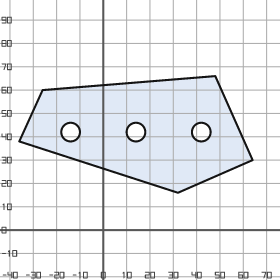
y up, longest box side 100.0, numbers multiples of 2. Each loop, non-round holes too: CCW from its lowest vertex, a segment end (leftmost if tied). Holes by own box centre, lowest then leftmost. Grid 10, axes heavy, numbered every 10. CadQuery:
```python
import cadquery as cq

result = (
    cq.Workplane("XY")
    .moveTo(32.0, 16.0)
    .lineTo(64.0, 30.0)
    .lineTo(48.0, 66.0)
    .lineTo(-26.0, 60.0)
    .lineTo(-36.0, 38.0)
    .close()
    .moveTo(-14.0, 42.0)
    .circle(4.0)
    .moveTo(14.0, 42.0)
    .circle(4.0)
    .moveTo(42.0, 42.0)
    .circle(4.0)
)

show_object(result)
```